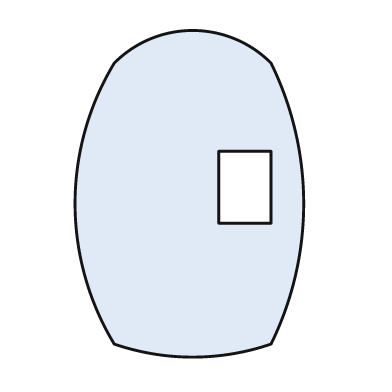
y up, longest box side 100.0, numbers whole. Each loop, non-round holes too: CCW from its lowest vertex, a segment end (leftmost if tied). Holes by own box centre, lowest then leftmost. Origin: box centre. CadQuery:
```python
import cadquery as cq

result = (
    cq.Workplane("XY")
    .moveTo(-23.0, -46.0)
    .threePointArc((1.0, -50.0), (25.0, -46.0))
    .threePointArc((35.0, -3.0), (25.0, 40.0))
    .threePointArc((1.0, 50.0), (-23.0, 40.0))
    .threePointArc((-35.0, -3.0), (-23.0, -46.0))
    .close()
    .moveTo(9.0, -9.0)
    .lineTo(25.0, -9.0)
    .lineTo(25.0, 13.0)
    .lineTo(9.0, 13.0)
    .close()
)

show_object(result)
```